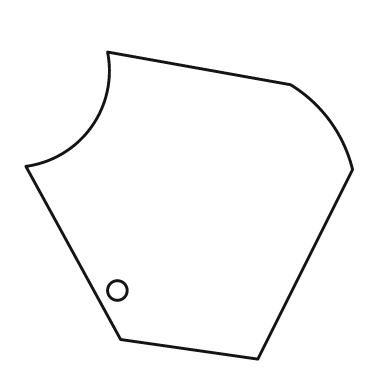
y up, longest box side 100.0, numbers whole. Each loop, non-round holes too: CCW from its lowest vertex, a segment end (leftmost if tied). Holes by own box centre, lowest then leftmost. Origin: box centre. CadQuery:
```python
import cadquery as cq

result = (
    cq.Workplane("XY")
    .moveTo(21.0, -47.0)
    .lineTo(50.0, 11.0)
    .threePointArc((43.0, 26.0), (31.0, 37.0))
    .lineTo(-25.0, 47.0)
    .threePointArc((-30.0, 24.0), (-50.0, 12.0))
    .lineTo(-21.0, -41.0)
    .close()
    .moveTo(-22.0, -26.0)
    .circle(3.0)
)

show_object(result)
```